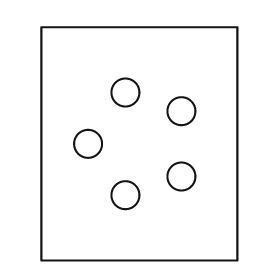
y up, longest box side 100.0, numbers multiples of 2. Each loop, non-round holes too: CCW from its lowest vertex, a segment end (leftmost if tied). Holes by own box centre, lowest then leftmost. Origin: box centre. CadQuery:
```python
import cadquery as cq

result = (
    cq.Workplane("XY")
    .moveTo(-42.0, -50.0)
    .lineTo(42.0, -50.0)
    .lineTo(42.0, 50.0)
    .lineTo(-42.0, 50.0)
    .close()
    .moveTo(-6.0, -22.0)
    .circle(6.0)
    .moveTo(18.0, -14.0)
    .circle(6.0)
    .moveTo(-22.0, 0.0)
    .circle(6.0)
    .moveTo(18.0, 14.0)
    .circle(6.0)
    .moveTo(-6.0, 22.0)
    .circle(6.0)
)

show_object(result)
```